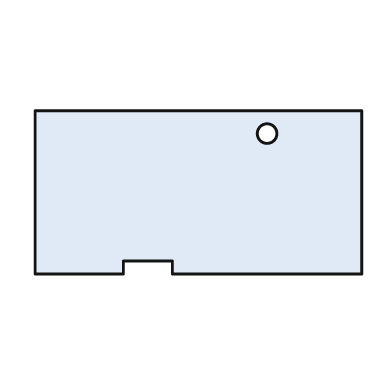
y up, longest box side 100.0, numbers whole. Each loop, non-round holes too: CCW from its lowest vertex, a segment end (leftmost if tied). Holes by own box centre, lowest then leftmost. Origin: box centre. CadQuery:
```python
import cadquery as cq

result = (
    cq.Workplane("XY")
    .moveTo(-50.0, -25.0)
    .lineTo(-23.0, -25.0)
    .lineTo(-23.0, -21.0)
    .lineTo(-8.0, -21.0)
    .lineTo(-8.0, -25.0)
    .lineTo(50.0, -25.0)
    .lineTo(50.0, 25.0)
    .lineTo(-50.0, 25.0)
    .close()
    .moveTo(21.0, 18.0)
    .circle(3.0)
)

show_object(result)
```